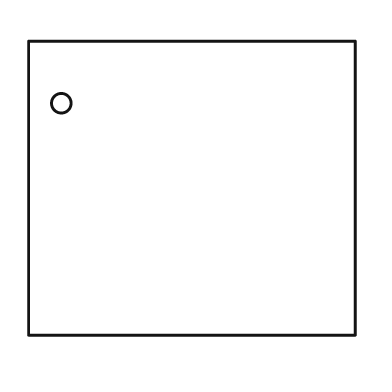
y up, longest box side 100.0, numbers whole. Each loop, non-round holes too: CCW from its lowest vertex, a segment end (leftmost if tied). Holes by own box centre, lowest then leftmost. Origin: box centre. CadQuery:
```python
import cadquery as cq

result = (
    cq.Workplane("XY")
    .moveTo(-50.0, -45.0)
    .lineTo(50.0, -45.0)
    .lineTo(50.0, 45.0)
    .lineTo(-50.0, 45.0)
    .close()
    .moveTo(-40.0, 26.0)
    .circle(3.0)
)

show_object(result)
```